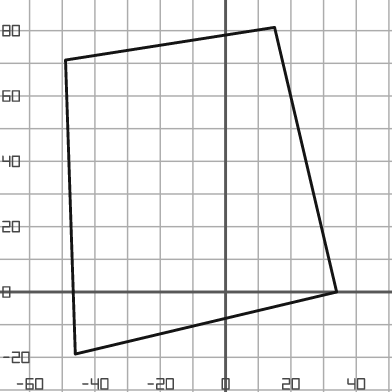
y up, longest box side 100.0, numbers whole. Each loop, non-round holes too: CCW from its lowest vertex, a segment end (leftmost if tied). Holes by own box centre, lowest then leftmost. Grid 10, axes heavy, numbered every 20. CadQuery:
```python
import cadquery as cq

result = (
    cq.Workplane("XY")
    .moveTo(-46.0, -19.0)
    .lineTo(34.0, 0.0)
    .lineTo(15.0, 81.0)
    .lineTo(-49.0, 71.0)
    .close()
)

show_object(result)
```